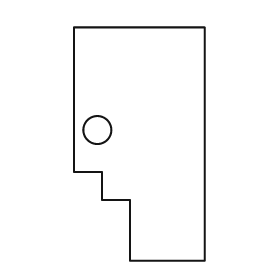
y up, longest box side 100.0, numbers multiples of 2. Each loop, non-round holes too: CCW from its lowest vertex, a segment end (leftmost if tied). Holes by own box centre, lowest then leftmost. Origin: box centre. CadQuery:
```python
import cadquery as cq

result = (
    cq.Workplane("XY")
    .moveTo(-4.0, -50.0)
    .lineTo(28.0, -50.0)
    .lineTo(28.0, 50.0)
    .lineTo(-28.0, 50.0)
    .lineTo(-28.0, -12.0)
    .lineTo(-16.0, -12.0)
    .lineTo(-16.0, -24.0)
    .lineTo(-4.0, -24.0)
    .close()
    .moveTo(-18.0, 6.0)
    .circle(6.0)
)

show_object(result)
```